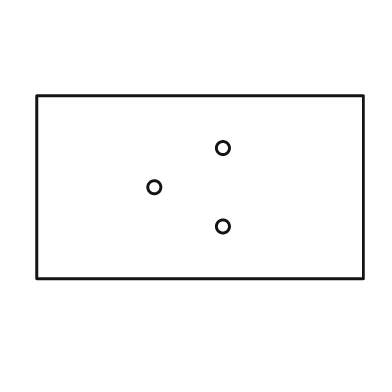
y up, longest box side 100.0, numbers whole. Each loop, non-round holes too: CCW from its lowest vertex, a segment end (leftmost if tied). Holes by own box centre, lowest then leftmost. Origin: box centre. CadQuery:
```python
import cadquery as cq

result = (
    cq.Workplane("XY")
    .moveTo(-50.0, -28.0)
    .lineTo(50.0, -28.0)
    .lineTo(50.0, 28.0)
    .lineTo(-50.0, 28.0)
    .close()
    .moveTo(7.0, -12.0)
    .circle(2.0)
    .moveTo(-14.0, 0.0)
    .circle(2.0)
    .moveTo(7.0, 12.0)
    .circle(2.0)
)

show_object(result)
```